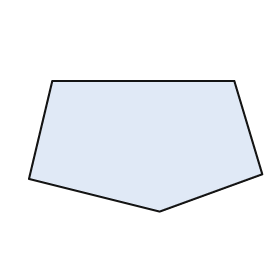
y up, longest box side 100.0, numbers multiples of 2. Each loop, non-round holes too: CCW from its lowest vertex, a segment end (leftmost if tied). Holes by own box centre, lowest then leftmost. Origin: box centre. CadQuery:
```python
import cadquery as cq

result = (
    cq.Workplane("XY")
    .moveTo(6.0, -28.0)
    .lineTo(50.0, -12.0)
    .lineTo(38.0, 28.0)
    .lineTo(-40.0, 28.0)
    .lineTo(-50.0, -14.0)
    .close()
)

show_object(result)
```